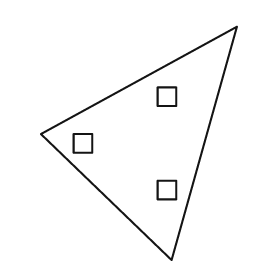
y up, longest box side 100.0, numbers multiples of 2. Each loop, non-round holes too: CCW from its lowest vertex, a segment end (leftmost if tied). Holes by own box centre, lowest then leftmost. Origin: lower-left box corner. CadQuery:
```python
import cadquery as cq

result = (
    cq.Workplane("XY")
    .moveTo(56.0, 0.0)
    .lineTo(84.0, 100.0)
    .lineTo(0.0, 54.0)
    .close()
    .moveTo(50.0, 26.0)
    .lineTo(58.0, 26.0)
    .lineTo(58.0, 34.0)
    .lineTo(50.0, 34.0)
    .close()
    .moveTo(14.0, 46.0)
    .lineTo(22.0, 46.0)
    .lineTo(22.0, 54.0)
    .lineTo(14.0, 54.0)
    .close()
    .moveTo(50.0, 66.0)
    .lineTo(58.0, 66.0)
    .lineTo(58.0, 74.0)
    .lineTo(50.0, 74.0)
    .close()
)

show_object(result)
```